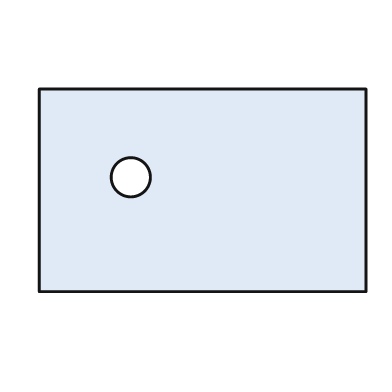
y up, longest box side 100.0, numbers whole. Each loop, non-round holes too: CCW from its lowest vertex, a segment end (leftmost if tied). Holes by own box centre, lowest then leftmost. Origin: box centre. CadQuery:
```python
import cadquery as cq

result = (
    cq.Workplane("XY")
    .moveTo(-50.0, -31.0)
    .lineTo(50.0, -31.0)
    .lineTo(50.0, 31.0)
    .lineTo(-50.0, 31.0)
    .close()
    .moveTo(-22.0, 4.0)
    .circle(6.0)
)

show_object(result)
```